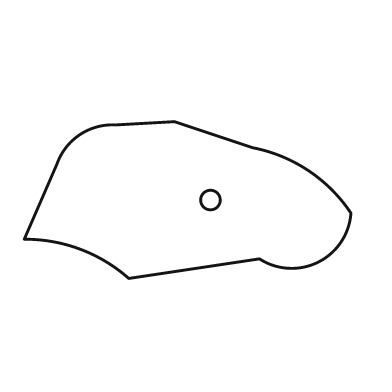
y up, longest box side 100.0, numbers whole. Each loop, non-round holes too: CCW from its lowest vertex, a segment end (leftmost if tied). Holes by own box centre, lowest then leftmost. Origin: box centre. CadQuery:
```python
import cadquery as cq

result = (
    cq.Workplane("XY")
    .moveTo(-18.0, -24.0)
    .lineTo(22.0, -18.0)
    .threePointArc((40.0, -19.0), (50.0, -4.0))
    .threePointArc((37.0, 9.0), (20.0, 16.0))
    .lineTo(-4.0, 24.0)
    .lineTo(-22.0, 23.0)
    .threePointArc((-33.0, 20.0), (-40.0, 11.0))
    .lineTo(-50.0, -12.0)
    .threePointArc((-33.0, -15.0), (-18.0, -24.0))
    .close()
    .moveTo(7.0, 0.0)
    .circle(3.0)
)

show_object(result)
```